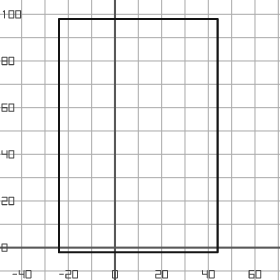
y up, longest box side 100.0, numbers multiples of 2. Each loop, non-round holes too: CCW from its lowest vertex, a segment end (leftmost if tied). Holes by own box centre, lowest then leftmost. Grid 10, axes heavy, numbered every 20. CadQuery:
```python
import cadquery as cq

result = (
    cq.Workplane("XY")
    .moveTo(-24.0, -2.0)
    .lineTo(44.0, -2.0)
    .lineTo(44.0, 98.0)
    .lineTo(-24.0, 98.0)
    .close()
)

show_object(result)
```